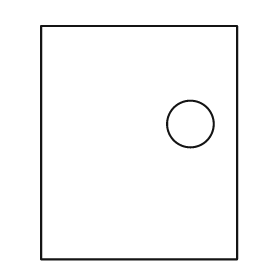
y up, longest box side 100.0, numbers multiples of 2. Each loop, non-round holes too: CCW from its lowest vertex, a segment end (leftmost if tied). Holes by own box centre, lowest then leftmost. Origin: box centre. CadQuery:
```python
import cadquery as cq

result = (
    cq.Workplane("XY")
    .moveTo(-42.0, -50.0)
    .lineTo(42.0, -50.0)
    .lineTo(42.0, 50.0)
    .lineTo(-42.0, 50.0)
    .close()
    .moveTo(22.0, 8.0)
    .circle(10.0)
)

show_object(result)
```